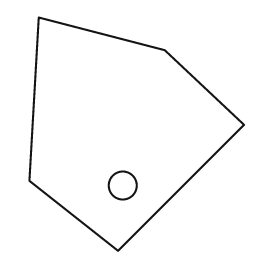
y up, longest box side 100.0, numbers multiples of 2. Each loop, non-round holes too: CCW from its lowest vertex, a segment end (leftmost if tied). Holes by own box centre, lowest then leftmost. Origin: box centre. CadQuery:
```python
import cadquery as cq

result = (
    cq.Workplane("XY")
    .moveTo(-8.0, -50.0)
    .lineTo(46.0, 4.0)
    .lineTo(12.0, 36.0)
    .lineTo(-42.0, 50.0)
    .lineTo(-46.0, -20.0)
    .close()
    .moveTo(-6.0, -22.0)
    .circle(6.0)
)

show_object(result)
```